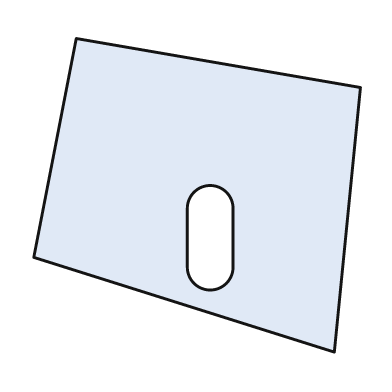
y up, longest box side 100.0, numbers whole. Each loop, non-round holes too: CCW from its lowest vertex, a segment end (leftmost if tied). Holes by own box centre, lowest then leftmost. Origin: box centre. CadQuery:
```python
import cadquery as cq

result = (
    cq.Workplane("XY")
    .moveTo(42.0, -48.0)
    .lineTo(50.0, 33.0)
    .lineTo(-37.0, 48.0)
    .lineTo(-50.0, -19.0)
    .close()
    .moveTo(-3.0, -22.0)
    .threePointArc((4.0, -29.0), (11.0, -22.0))
    .lineTo(11.0, -4.0)
    .threePointArc((4.0, 3.0), (-3.0, -4.0))
    .close()
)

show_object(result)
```